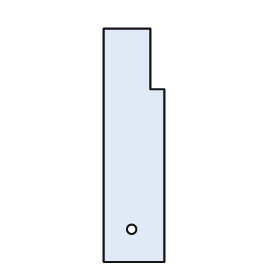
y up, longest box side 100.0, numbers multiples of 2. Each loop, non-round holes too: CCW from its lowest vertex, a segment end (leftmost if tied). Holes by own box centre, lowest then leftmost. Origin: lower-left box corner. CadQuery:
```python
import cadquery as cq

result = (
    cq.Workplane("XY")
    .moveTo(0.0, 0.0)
    .lineTo(26.0, 0.0)
    .lineTo(26.0, 74.0)
    .lineTo(20.0, 74.0)
    .lineTo(20.0, 100.0)
    .lineTo(0.0, 100.0)
    .close()
    .moveTo(12.0, 14.0)
    .circle(2.0)
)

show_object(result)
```